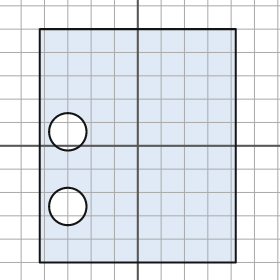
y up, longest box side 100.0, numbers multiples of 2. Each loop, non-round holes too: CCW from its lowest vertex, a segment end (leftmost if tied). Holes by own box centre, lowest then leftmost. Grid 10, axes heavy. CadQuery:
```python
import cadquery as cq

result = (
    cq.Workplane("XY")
    .moveTo(-42.0, -50.0)
    .lineTo(42.0, -50.0)
    .lineTo(42.0, 50.0)
    .lineTo(-42.0, 50.0)
    .close()
    .moveTo(-30.0, -26.0)
    .circle(8.0)
    .moveTo(-30.0, 6.0)
    .circle(8.0)
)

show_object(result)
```